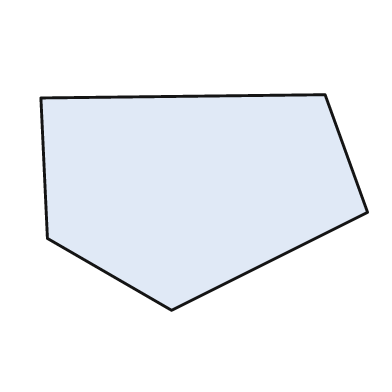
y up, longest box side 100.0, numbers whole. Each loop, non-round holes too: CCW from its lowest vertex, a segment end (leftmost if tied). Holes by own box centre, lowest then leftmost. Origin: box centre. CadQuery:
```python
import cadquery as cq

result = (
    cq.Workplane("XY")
    .moveTo(-10.0, -33.0)
    .lineTo(50.0, -3.0)
    .lineTo(37.0, 33.0)
    .lineTo(-50.0, 32.0)
    .lineTo(-48.0, -11.0)
    .close()
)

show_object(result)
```